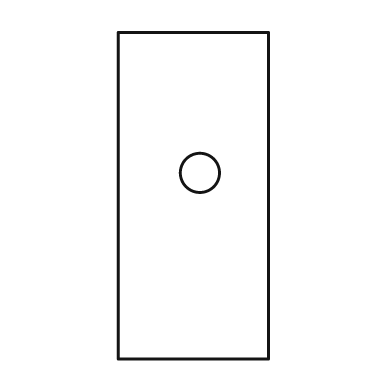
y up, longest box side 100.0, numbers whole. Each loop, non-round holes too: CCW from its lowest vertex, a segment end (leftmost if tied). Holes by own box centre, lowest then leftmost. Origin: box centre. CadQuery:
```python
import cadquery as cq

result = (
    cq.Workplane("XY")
    .moveTo(-23.0, -50.0)
    .lineTo(23.0, -50.0)
    .lineTo(23.0, 50.0)
    .lineTo(-23.0, 50.0)
    .close()
    .moveTo(2.0, 7.0)
    .circle(6.0)
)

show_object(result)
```